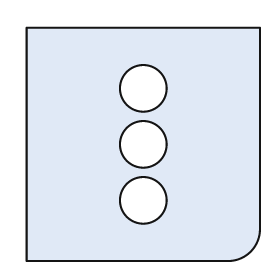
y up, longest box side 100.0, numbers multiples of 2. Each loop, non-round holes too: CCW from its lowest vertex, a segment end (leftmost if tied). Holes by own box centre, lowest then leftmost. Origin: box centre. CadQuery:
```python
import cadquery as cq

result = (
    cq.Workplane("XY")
    .moveTo(-50.0, -50.0)
    .lineTo(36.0, -50.0)
    .threePointArc((46.0, -46.0), (50.0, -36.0))
    .lineTo(50.0, 50.0)
    .lineTo(-50.0, 50.0)
    .close()
    .moveTo(0.0, -24.0)
    .circle(10.0)
    .moveTo(0.0, 0.0)
    .circle(10.0)
    .moveTo(0.0, 24.0)
    .circle(10.0)
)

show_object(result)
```